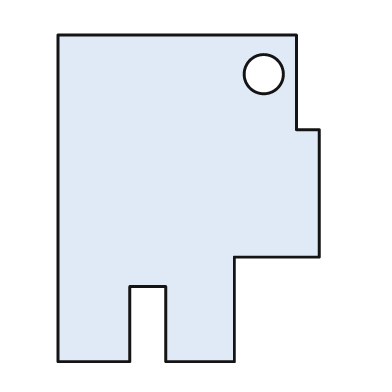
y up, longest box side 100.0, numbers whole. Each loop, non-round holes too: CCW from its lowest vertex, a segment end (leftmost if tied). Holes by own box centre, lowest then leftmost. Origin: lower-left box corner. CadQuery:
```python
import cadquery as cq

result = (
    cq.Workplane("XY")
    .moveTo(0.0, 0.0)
    .lineTo(22.0, 0.0)
    .lineTo(22.0, 23.0)
    .lineTo(33.0, 23.0)
    .lineTo(33.0, 0.0)
    .lineTo(54.0, 0.0)
    .lineTo(54.0, 32.0)
    .lineTo(80.0, 32.0)
    .lineTo(80.0, 71.0)
    .lineTo(73.0, 71.0)
    .lineTo(73.0, 100.0)
    .lineTo(0.0, 100.0)
    .close()
    .moveTo(63.0, 88.0)
    .circle(6.0)
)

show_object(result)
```